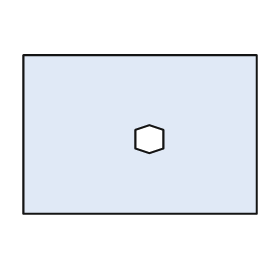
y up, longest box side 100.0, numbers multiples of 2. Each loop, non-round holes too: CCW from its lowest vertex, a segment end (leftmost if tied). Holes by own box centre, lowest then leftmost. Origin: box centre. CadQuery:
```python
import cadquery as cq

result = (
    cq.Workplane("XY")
    .moveTo(-50.0, -34.0)
    .lineTo(50.0, -34.0)
    .lineTo(50.0, 34.0)
    .lineTo(-50.0, 34.0)
    .close()
    .moveTo(4.0, -8.0)
    .lineTo(10.0, -6.0)
    .lineTo(10.0, 2.0)
    .lineTo(4.0, 4.0)
    .lineTo(-2.0, 2.0)
    .lineTo(-2.0, -6.0)
    .close()
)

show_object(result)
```